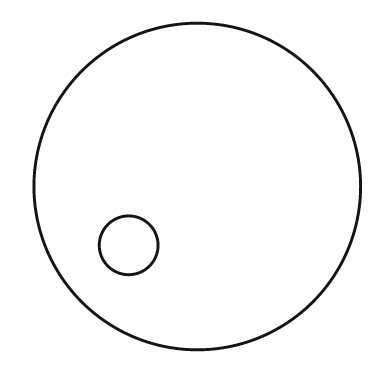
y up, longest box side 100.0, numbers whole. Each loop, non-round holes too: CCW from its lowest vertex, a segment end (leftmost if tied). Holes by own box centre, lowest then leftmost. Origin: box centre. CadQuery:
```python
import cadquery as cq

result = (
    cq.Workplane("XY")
    .moveTo(0.0, 0.0)
    .circle(50.0)
    .moveTo(-21.0, -18.0)
    .circle(9.0)
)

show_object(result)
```